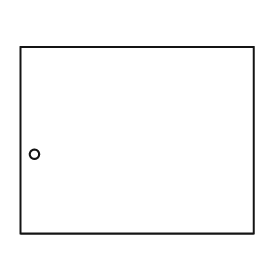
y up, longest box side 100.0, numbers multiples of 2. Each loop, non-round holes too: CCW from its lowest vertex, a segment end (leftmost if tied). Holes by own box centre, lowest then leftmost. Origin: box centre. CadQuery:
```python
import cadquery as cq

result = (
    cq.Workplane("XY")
    .moveTo(-50.0, -40.0)
    .lineTo(50.0, -40.0)
    .lineTo(50.0, 40.0)
    .lineTo(-50.0, 40.0)
    .close()
    .moveTo(-44.0, -6.0)
    .circle(2.0)
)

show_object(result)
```